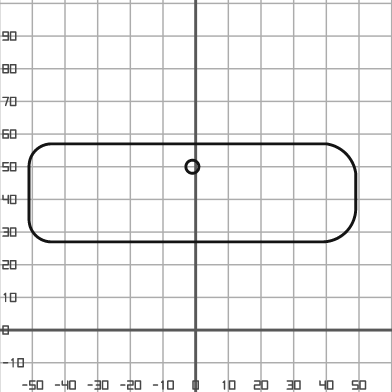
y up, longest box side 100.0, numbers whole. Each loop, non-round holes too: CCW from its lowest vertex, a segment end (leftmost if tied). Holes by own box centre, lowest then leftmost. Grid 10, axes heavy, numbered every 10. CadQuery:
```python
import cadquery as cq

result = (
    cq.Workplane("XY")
    .moveTo(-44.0, 27.0)
    .lineTo(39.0, 27.0)
    .threePointArc((46.0, 30.0), (49.0, 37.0))
    .lineTo(49.0, 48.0)
    .threePointArc((46.0, 54.0), (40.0, 57.0))
    .lineTo(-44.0, 57.0)
    .threePointArc((-49.0, 55.0), (-51.0, 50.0))
    .lineTo(-51.0, 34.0)
    .threePointArc((-49.0, 29.0), (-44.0, 27.0))
    .close()
    .moveTo(-1.0, 50.0)
    .circle(2.0)
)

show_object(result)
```